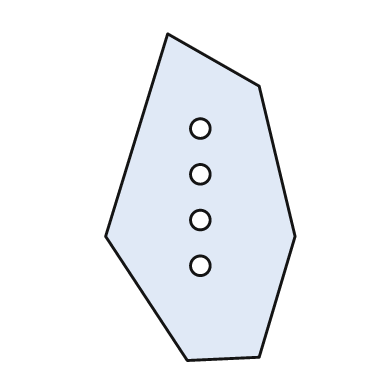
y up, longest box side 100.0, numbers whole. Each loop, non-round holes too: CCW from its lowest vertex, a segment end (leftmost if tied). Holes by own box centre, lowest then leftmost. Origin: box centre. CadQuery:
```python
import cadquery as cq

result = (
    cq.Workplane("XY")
    .moveTo(-4.0, -50.0)
    .lineTo(18.0, -49.0)
    .lineTo(29.0, -12.0)
    .lineTo(18.0, 34.0)
    .lineTo(-10.0, 50.0)
    .lineTo(-29.0, -12.0)
    .close()
    .moveTo(0.0, -21.0)
    .circle(3.0)
    .moveTo(0.0, -7.0)
    .circle(3.0)
    .moveTo(0.0, 7.0)
    .circle(3.0)
    .moveTo(0.0, 21.0)
    .circle(3.0)
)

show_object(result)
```